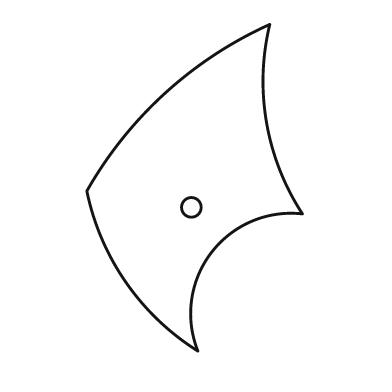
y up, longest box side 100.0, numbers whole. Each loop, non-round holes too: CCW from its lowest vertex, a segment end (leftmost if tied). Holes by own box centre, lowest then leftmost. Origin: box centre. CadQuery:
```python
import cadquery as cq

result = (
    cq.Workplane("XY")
    .moveTo(1.0, -50.0)
    .threePointArc((5.0, -20.0), (33.0, -8.0))
    .threePointArc((22.0, 20.0), (23.0, 50.0))
    .threePointArc((-9.0, 29.0), (-33.0, -1.0))
    .threePointArc((-21.0, -29.0), (1.0, -50.0))
    .close()
    .moveTo(-1.0, -6.0)
    .circle(3.0)
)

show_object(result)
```